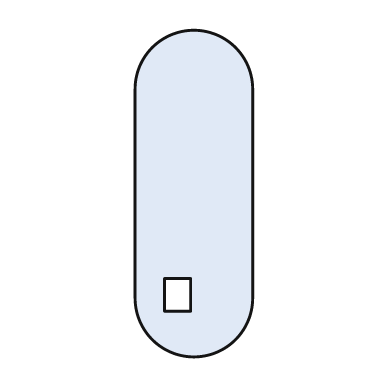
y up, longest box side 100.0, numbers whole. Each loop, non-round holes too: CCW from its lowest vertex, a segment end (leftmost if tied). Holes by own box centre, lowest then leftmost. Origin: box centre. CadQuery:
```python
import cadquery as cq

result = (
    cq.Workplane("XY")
    .moveTo(-18.0, -32.0)
    .threePointArc((0.0, -50.0), (18.0, -32.0))
    .lineTo(18.0, 32.0)
    .threePointArc((0.0, 50.0), (-18.0, 32.0))
    .close()
    .moveTo(-9.0, -36.0)
    .lineTo(-1.0, -36.0)
    .lineTo(-1.0, -26.0)
    .lineTo(-9.0, -26.0)
    .close()
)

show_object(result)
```